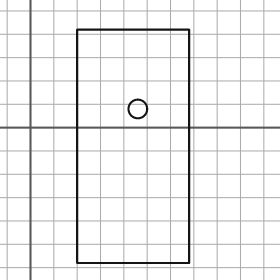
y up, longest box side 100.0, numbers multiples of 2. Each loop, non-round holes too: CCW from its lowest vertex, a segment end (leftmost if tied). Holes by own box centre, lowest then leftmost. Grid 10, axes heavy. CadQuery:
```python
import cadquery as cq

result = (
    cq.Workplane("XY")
    .moveTo(20.0, -58.0)
    .lineTo(68.0, -58.0)
    .lineTo(68.0, 42.0)
    .lineTo(20.0, 42.0)
    .close()
    .moveTo(46.0, 8.0)
    .circle(4.0)
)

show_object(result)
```